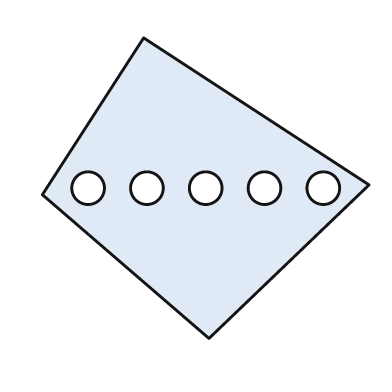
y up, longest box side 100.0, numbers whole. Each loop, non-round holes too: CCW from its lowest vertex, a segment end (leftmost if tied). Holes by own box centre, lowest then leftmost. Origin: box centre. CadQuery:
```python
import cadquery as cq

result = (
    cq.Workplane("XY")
    .moveTo(1.0, -46.0)
    .lineTo(50.0, 1.0)
    .lineTo(-19.0, 46.0)
    .lineTo(-50.0, -2.0)
    .close()
    .moveTo(-36.0, 0.0)
    .circle(5.0)
    .moveTo(-18.0, 0.0)
    .circle(5.0)
    .moveTo(0.0, 0.0)
    .circle(5.0)
    .moveTo(18.0, 0.0)
    .circle(5.0)
    .moveTo(36.0, 0.0)
    .circle(5.0)
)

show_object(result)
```